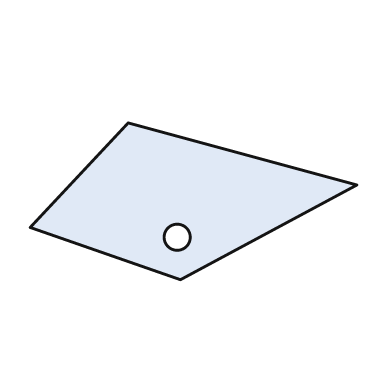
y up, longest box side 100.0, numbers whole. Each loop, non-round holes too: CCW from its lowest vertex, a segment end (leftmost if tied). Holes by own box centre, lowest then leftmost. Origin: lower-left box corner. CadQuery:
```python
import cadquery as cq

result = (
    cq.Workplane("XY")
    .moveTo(46.0, 0.0)
    .lineTo(100.0, 29.0)
    .lineTo(30.0, 48.0)
    .lineTo(0.0, 16.0)
    .close()
    .moveTo(45.0, 13.0)
    .circle(4.0)
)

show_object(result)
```